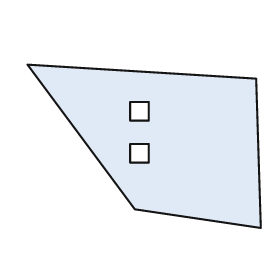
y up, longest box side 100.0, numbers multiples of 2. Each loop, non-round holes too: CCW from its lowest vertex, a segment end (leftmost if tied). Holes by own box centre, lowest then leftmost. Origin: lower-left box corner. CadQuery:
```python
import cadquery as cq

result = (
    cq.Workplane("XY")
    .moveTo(100.0, 0.0)
    .lineTo(98.0, 64.0)
    .lineTo(0.0, 70.0)
    .lineTo(46.0, 8.0)
    .close()
    .moveTo(44.0, 28.0)
    .lineTo(52.0, 28.0)
    .lineTo(52.0, 36.0)
    .lineTo(44.0, 36.0)
    .close()
    .moveTo(44.0, 46.0)
    .lineTo(52.0, 46.0)
    .lineTo(52.0, 54.0)
    .lineTo(44.0, 54.0)
    .close()
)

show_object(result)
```